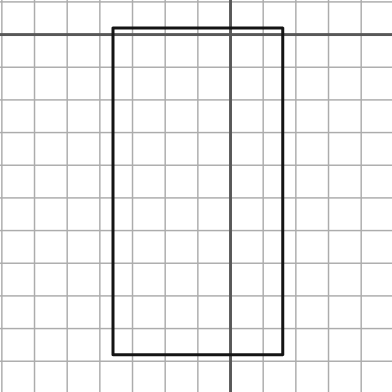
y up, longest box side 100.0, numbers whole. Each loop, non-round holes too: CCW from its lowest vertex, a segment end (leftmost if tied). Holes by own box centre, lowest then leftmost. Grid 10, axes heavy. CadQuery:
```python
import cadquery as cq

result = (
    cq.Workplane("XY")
    .moveTo(-36.0, -98.0)
    .lineTo(16.0, -98.0)
    .lineTo(16.0, 2.0)
    .lineTo(-36.0, 2.0)
    .close()
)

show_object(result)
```